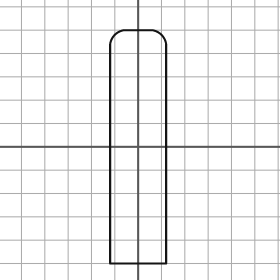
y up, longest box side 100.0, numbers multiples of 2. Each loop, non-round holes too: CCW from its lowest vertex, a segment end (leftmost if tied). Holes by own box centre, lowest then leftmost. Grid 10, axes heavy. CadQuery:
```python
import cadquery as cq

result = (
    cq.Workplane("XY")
    .moveTo(-12.0, -50.0)
    .lineTo(12.0, -50.0)
    .lineTo(12.0, 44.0)
    .threePointArc((10.0, 48.0), (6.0, 50.0))
    .lineTo(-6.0, 50.0)
    .threePointArc((-10.0, 48.0), (-12.0, 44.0))
    .close()
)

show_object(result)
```